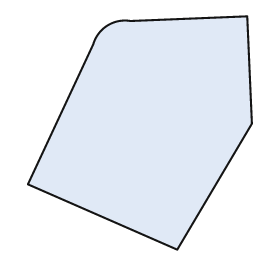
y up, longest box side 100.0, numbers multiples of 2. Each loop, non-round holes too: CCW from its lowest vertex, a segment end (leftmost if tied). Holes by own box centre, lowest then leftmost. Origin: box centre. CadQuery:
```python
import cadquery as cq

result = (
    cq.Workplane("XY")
    .moveTo(16.0, -50.0)
    .lineTo(48.0, 4.0)
    .lineTo(46.0, 50.0)
    .lineTo(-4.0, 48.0)
    .threePointArc((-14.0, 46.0), (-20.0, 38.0))
    .lineTo(-48.0, -22.0)
    .close()
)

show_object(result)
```